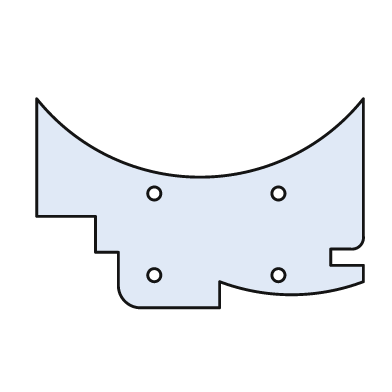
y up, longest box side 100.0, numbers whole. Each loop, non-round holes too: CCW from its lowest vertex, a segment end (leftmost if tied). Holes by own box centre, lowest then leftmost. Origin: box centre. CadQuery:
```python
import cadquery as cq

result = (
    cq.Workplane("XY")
    .moveTo(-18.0, -32.0)
    .lineTo(6.0, -32.0)
    .lineTo(6.0, -24.0)
    .threePointArc((28.0, -28.0), (50.0, -24.0))
    .lineTo(50.0, -19.0)
    .lineTo(40.0, -19.0)
    .lineTo(40.0, -14.0)
    .lineTo(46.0, -14.0)
    .threePointArc((49.0, -13.0), (50.0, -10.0))
    .lineTo(50.0, 32.0)
    .threePointArc((0.0, 8.0), (-50.0, 32.0))
    .lineTo(-50.0, -4.0)
    .lineTo(-32.0, -4.0)
    .lineTo(-32.0, -15.0)
    .lineTo(-25.0, -15.0)
    .lineTo(-25.0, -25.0)
    .threePointArc((-23.0, -30.0), (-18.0, -32.0))
    .close()
    .moveTo(-14.0, -22.0)
    .circle(2.0)
    .moveTo(24.0, -22.0)
    .circle(2.0)
    .moveTo(-14.0, 3.0)
    .circle(2.0)
    .moveTo(24.0, 3.0)
    .circle(2.0)
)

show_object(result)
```